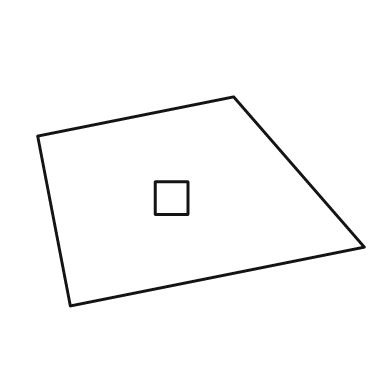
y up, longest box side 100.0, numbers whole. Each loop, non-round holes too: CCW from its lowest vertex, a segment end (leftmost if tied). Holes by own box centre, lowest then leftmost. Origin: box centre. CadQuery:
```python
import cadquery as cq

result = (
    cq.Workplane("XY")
    .moveTo(-40.0, -32.0)
    .lineTo(50.0, -14.0)
    .lineTo(10.0, 32.0)
    .lineTo(-50.0, 20.0)
    .close()
    .moveTo(-14.0, -4.0)
    .lineTo(-4.0, -4.0)
    .lineTo(-4.0, 6.0)
    .lineTo(-14.0, 6.0)
    .close()
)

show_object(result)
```